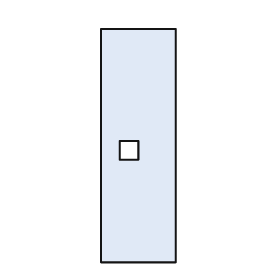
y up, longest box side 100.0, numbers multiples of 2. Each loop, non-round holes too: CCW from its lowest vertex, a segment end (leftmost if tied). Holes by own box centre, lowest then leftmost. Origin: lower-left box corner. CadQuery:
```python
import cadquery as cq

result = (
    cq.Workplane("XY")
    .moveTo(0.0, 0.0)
    .lineTo(32.0, 0.0)
    .lineTo(32.0, 100.0)
    .lineTo(0.0, 100.0)
    .close()
    .moveTo(8.0, 44.0)
    .lineTo(16.0, 44.0)
    .lineTo(16.0, 52.0)
    .lineTo(8.0, 52.0)
    .close()
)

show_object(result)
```